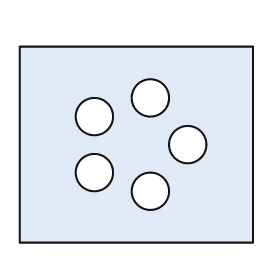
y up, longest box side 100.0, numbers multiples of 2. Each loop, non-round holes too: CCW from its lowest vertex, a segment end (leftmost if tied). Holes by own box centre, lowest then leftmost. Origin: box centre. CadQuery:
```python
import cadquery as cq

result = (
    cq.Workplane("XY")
    .moveTo(-50.0, -42.0)
    .lineTo(50.0, -42.0)
    .lineTo(50.0, 42.0)
    .lineTo(-50.0, 42.0)
    .close()
    .moveTo(6.0, -20.0)
    .circle(8.0)
    .moveTo(-18.0, -12.0)
    .circle(8.0)
    .moveTo(22.0, 0.0)
    .circle(8.0)
    .moveTo(-18.0, 12.0)
    .circle(8.0)
    .moveTo(6.0, 20.0)
    .circle(8.0)
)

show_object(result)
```